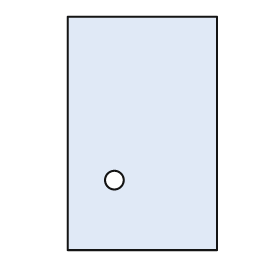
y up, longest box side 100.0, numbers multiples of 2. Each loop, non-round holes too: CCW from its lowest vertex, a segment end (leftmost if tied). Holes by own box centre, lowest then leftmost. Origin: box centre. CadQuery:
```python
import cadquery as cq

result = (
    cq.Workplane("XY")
    .moveTo(-32.0, -50.0)
    .lineTo(32.0, -50.0)
    .lineTo(32.0, 50.0)
    .lineTo(-32.0, 50.0)
    .close()
    .moveTo(-12.0, -20.0)
    .circle(4.0)
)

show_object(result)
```